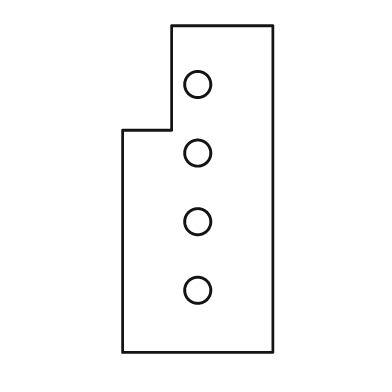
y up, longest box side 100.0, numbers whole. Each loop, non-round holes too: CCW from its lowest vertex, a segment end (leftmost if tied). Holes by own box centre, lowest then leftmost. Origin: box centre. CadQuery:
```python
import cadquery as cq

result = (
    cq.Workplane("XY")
    .moveTo(-23.0, -50.0)
    .lineTo(23.0, -50.0)
    .lineTo(23.0, 50.0)
    .lineTo(-8.0, 50.0)
    .lineTo(-8.0, 18.0)
    .lineTo(-23.0, 18.0)
    .close()
    .moveTo(0.0, -31.0)
    .circle(4.0)
    .moveTo(0.0, -10.0)
    .circle(4.0)
    .moveTo(0.0, 11.0)
    .circle(4.0)
    .moveTo(0.0, 32.0)
    .circle(4.0)
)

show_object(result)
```